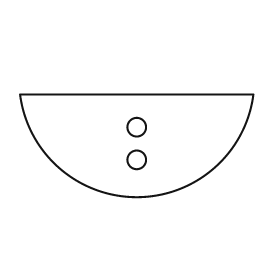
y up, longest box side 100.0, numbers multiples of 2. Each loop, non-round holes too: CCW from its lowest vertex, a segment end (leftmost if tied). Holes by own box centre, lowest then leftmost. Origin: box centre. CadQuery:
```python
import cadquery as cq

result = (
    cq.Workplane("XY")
    .moveTo(-50.0, 22.0)
    .threePointArc((0.0, -22.0), (50.0, 22.0))
    .close()
    .moveTo(0.0, -6.0)
    .circle(4.0)
    .moveTo(0.0, 8.0)
    .circle(4.0)
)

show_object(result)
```